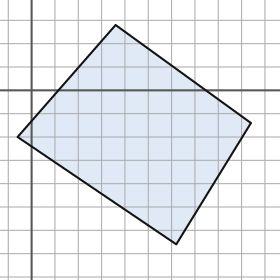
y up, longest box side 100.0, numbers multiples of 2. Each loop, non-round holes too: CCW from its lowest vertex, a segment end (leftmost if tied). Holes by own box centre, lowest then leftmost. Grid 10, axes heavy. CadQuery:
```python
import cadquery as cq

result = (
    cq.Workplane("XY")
    .moveTo(62.0, -66.0)
    .lineTo(94.0, -14.0)
    .lineTo(36.0, 28.0)
    .lineTo(-6.0, -20.0)
    .close()
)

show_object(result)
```